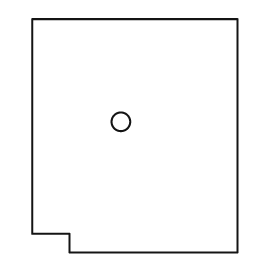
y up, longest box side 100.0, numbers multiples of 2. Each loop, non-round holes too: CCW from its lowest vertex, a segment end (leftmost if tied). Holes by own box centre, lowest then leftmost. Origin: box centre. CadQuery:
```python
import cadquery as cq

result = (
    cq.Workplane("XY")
    .moveTo(-28.0, -50.0)
    .lineTo(44.0, -50.0)
    .lineTo(44.0, 50.0)
    .lineTo(-44.0, 50.0)
    .lineTo(-44.0, -42.0)
    .lineTo(-28.0, -42.0)
    .close()
    .moveTo(-6.0, 6.0)
    .circle(4.0)
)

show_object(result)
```